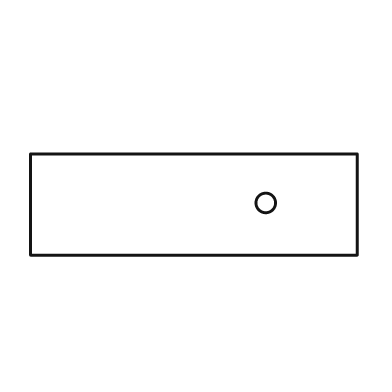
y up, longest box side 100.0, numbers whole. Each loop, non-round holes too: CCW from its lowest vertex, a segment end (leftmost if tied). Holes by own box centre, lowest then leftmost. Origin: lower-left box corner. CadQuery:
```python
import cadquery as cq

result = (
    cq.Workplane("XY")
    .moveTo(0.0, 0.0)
    .lineTo(100.0, 0.0)
    .lineTo(100.0, 31.0)
    .lineTo(0.0, 31.0)
    .close()
    .moveTo(72.0, 16.0)
    .circle(3.0)
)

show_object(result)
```